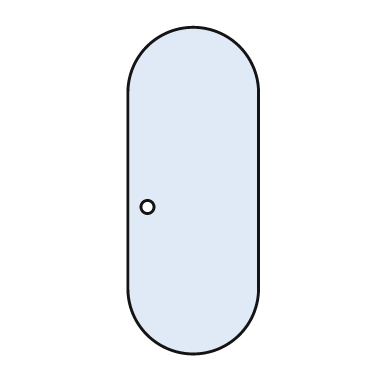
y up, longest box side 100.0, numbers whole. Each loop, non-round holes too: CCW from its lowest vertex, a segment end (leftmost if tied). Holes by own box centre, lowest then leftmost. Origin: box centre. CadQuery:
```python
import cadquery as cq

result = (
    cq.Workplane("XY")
    .moveTo(-20.0, -30.0)
    .threePointArc((0.0, -50.0), (20.0, -30.0))
    .lineTo(20.0, 30.0)
    .threePointArc((0.0, 50.0), (-20.0, 30.0))
    .close()
    .moveTo(-14.0, -5.0)
    .circle(2.0)
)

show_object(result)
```